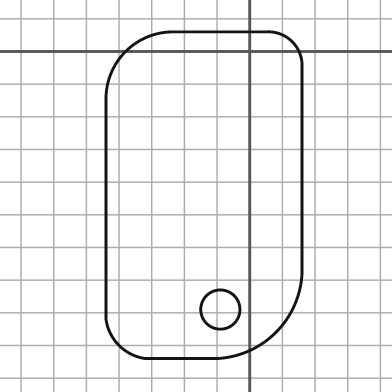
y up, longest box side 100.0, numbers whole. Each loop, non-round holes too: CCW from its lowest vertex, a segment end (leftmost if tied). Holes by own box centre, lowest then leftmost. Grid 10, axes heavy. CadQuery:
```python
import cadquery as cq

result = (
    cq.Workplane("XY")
    .moveTo(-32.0, -94.0)
    .lineTo(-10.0, -94.0)
    .threePointArc((8.0, -86.0), (16.0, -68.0))
    .lineTo(16.0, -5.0)
    .threePointArc((13.0, 3.0), (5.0, 6.0))
    .lineTo(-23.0, 6.0)
    .threePointArc((-38.0, 0.0), (-44.0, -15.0))
    .lineTo(-44.0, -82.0)
    .threePointArc((-40.0, -90.0), (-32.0, -94.0))
    .close()
    .moveTo(-9.0, -79.0)
    .circle(6.0)
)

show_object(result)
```